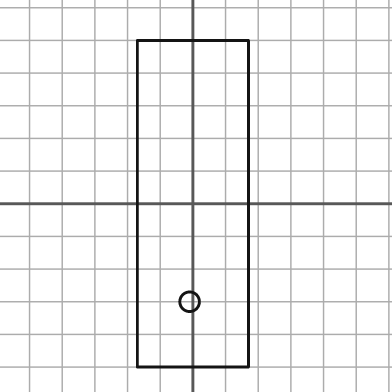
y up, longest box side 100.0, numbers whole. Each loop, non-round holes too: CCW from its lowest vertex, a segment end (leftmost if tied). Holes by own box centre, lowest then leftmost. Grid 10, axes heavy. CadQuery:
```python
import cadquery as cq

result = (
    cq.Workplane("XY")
    .moveTo(-17.0, -50.0)
    .lineTo(17.0, -50.0)
    .lineTo(17.0, 50.0)
    .lineTo(-17.0, 50.0)
    .close()
    .moveTo(-1.0, -30.0)
    .circle(3.0)
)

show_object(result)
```